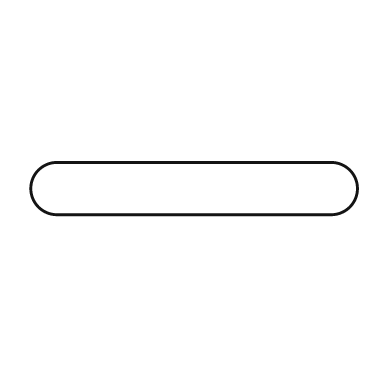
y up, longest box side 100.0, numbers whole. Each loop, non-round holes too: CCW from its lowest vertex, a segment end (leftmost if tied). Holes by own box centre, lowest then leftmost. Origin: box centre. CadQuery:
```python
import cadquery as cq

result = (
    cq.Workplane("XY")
    .moveTo(-42.0, -8.0)
    .lineTo(42.0, -8.0)
    .threePointArc((50.0, 0.0), (42.0, 8.0))
    .lineTo(-42.0, 8.0)
    .threePointArc((-50.0, 0.0), (-42.0, -8.0))
    .close()
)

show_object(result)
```